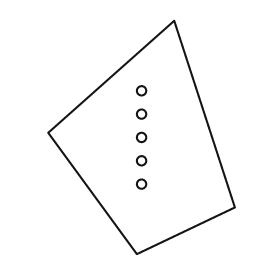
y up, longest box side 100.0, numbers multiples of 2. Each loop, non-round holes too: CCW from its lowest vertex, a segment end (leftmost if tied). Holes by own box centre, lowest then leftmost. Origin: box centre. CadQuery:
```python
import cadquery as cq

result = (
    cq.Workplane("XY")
    .moveTo(-2.0, -50.0)
    .lineTo(40.0, -30.0)
    .lineTo(14.0, 50.0)
    .lineTo(-40.0, 2.0)
    .close()
    .moveTo(0.0, -20.0)
    .circle(2.0)
    .moveTo(0.0, -10.0)
    .circle(2.0)
    .moveTo(0.0, 0.0)
    .circle(2.0)
    .moveTo(0.0, 10.0)
    .circle(2.0)
    .moveTo(0.0, 20.0)
    .circle(2.0)
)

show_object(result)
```